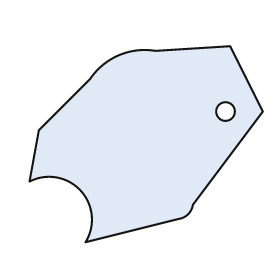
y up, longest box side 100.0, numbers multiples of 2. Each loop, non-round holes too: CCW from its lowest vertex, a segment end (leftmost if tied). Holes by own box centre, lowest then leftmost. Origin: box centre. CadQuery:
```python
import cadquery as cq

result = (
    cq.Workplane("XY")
    .moveTo(-26.0, -42.0)
    .lineTo(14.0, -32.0)
    .threePointArc((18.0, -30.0), (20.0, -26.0))
    .lineTo(50.0, 14.0)
    .lineTo(36.0, 42.0)
    .lineTo(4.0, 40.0)
    .threePointArc((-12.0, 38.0), (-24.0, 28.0))
    .lineTo(-46.0, 6.0)
    .lineTo(-50.0, -16.0)
    .threePointArc((-28.0, -20.0), (-26.0, -42.0))
    .close()
    .moveTo(34.0, 14.0)
    .circle(4.0)
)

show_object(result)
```